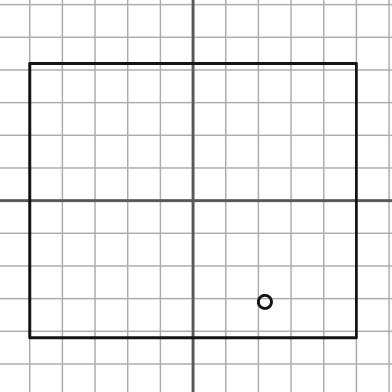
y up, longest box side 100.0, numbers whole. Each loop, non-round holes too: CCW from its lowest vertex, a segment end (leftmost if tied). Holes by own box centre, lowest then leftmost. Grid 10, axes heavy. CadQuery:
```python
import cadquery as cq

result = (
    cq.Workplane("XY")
    .moveTo(-50.0, -42.0)
    .lineTo(50.0, -42.0)
    .lineTo(50.0, 42.0)
    .lineTo(-50.0, 42.0)
    .close()
    .moveTo(22.0, -31.0)
    .circle(2.0)
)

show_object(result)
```